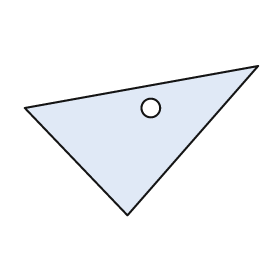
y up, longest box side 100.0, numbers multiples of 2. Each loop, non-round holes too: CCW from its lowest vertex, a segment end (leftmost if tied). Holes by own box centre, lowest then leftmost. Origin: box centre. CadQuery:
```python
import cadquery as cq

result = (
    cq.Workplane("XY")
    .moveTo(-6.0, -32.0)
    .lineTo(50.0, 32.0)
    .lineTo(-50.0, 14.0)
    .close()
    .moveTo(4.0, 14.0)
    .circle(4.0)
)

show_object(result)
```